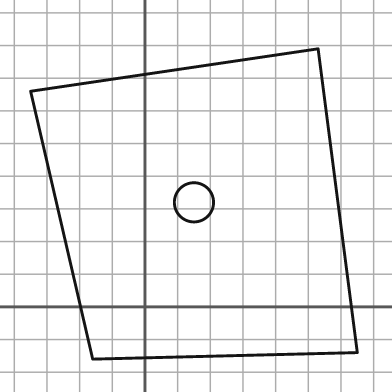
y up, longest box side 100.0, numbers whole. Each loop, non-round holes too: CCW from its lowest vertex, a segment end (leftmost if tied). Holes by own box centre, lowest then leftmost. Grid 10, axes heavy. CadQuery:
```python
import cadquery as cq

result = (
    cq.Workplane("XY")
    .moveTo(-16.0, -16.0)
    .lineTo(65.0, -14.0)
    .lineTo(53.0, 79.0)
    .lineTo(-35.0, 66.0)
    .close()
    .moveTo(15.0, 32.0)
    .circle(6.0)
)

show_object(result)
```